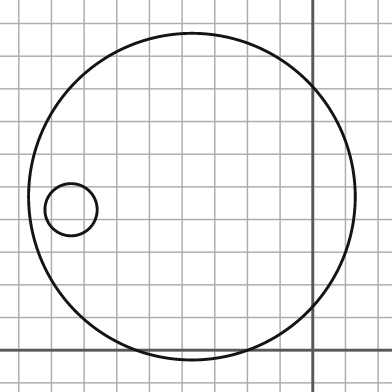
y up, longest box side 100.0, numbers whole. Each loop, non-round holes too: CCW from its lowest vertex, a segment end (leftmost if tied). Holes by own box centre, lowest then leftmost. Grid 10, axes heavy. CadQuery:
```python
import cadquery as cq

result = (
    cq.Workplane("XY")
    .moveTo(-37.0, 47.0)
    .circle(50.0)
    .moveTo(-74.0, 43.0)
    .circle(8.0)
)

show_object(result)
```